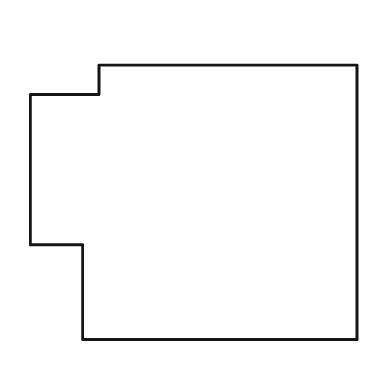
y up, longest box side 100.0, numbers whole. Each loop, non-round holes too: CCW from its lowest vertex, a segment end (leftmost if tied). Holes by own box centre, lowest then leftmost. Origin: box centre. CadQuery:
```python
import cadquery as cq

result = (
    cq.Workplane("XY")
    .moveTo(-34.0, -42.0)
    .lineTo(50.0, -42.0)
    .lineTo(50.0, 42.0)
    .lineTo(-29.0, 42.0)
    .lineTo(-29.0, 33.0)
    .lineTo(-50.0, 33.0)
    .lineTo(-50.0, -13.0)
    .lineTo(-34.0, -13.0)
    .close()
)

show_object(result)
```